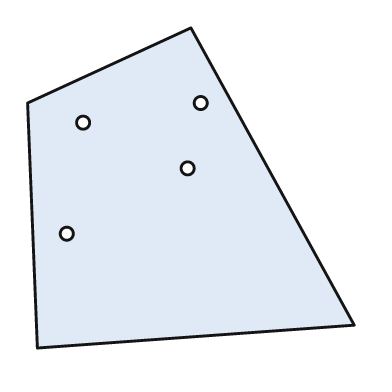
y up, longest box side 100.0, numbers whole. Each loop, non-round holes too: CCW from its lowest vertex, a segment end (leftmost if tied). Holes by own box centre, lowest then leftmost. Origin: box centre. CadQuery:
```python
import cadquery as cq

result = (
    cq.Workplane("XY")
    .moveTo(-47.0, -49.0)
    .lineTo(50.0, -42.0)
    .lineTo(0.0, 49.0)
    .lineTo(-50.0, 26.0)
    .close()
    .moveTo(-38.0, -14.0)
    .circle(2.0)
    .moveTo(-1.0, 6.0)
    .circle(2.0)
    .moveTo(-33.0, 20.0)
    .circle(2.0)
    .moveTo(3.0, 26.0)
    .circle(2.0)
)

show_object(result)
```